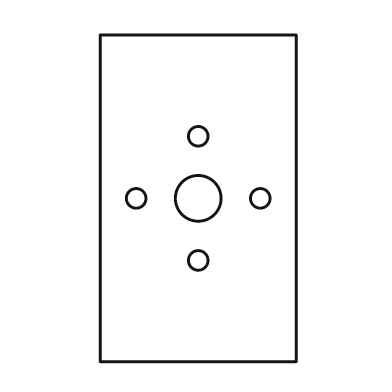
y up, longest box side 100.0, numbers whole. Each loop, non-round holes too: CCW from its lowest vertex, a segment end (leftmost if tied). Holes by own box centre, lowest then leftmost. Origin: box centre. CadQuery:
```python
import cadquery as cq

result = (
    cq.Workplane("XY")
    .moveTo(-30.0, -50.0)
    .lineTo(30.0, -50.0)
    .lineTo(30.0, 50.0)
    .lineTo(-30.0, 50.0)
    .close()
    .moveTo(0.0, -19.0)
    .circle(3.0)
    .moveTo(-19.0, 0.0)
    .circle(3.0)
    .moveTo(0.0, 0.0)
    .circle(7.0)
    .moveTo(19.0, 0.0)
    .circle(3.0)
    .moveTo(0.0, 19.0)
    .circle(3.0)
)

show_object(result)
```